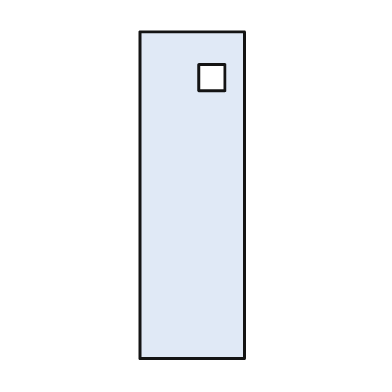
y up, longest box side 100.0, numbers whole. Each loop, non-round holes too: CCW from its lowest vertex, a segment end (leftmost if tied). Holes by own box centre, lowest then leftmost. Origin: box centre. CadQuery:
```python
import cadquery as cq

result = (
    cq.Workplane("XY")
    .moveTo(-16.0, -50.0)
    .lineTo(16.0, -50.0)
    .lineTo(16.0, 50.0)
    .lineTo(-16.0, 50.0)
    .close()
    .moveTo(2.0, 32.0)
    .lineTo(10.0, 32.0)
    .lineTo(10.0, 40.0)
    .lineTo(2.0, 40.0)
    .close()
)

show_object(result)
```